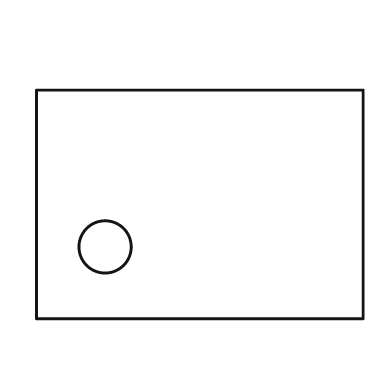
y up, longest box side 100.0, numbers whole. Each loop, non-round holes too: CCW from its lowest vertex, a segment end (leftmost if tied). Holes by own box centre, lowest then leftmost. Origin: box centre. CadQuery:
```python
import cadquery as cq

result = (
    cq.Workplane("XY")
    .moveTo(-50.0, -35.0)
    .lineTo(50.0, -35.0)
    .lineTo(50.0, 35.0)
    .lineTo(-50.0, 35.0)
    .close()
    .moveTo(-29.0, -13.0)
    .circle(8.0)
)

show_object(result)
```